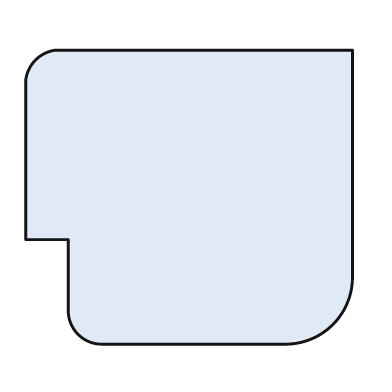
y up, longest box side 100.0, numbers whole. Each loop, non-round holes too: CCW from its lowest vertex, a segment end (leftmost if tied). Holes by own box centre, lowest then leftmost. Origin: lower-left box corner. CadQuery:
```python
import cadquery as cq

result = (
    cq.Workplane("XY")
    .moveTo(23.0, 0.0)
    .lineTo(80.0, 0.0)
    .threePointArc((94.0, 6.0), (100.0, 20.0))
    .lineTo(100.0, 90.0)
    .lineTo(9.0, 90.0)
    .threePointArc((3.0, 87.0), (0.0, 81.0))
    .lineTo(0.0, 32.0)
    .lineTo(13.0, 32.0)
    .lineTo(13.0, 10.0)
    .threePointArc((16.0, 3.0), (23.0, 0.0))
    .close()
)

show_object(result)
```